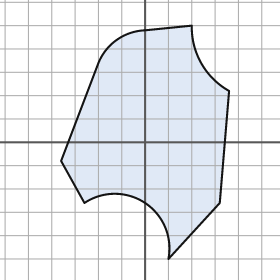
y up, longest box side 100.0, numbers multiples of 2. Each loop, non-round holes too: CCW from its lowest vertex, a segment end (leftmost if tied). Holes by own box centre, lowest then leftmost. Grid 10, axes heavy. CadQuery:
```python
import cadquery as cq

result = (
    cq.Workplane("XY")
    .moveTo(10.0, -50.0)
    .lineTo(32.0, -26.0)
    .lineTo(36.0, 22.0)
    .threePointArc((24.0, 34.0), (20.0, 50.0))
    .lineTo(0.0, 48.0)
    .threePointArc((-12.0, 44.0), (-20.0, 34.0))
    .lineTo(-36.0, -8.0)
    .lineTo(-26.0, -26.0)
    .threePointArc((0.0, -26.0), (10.0, -50.0))
    .close()
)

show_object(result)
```